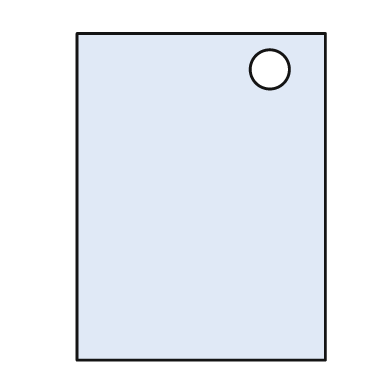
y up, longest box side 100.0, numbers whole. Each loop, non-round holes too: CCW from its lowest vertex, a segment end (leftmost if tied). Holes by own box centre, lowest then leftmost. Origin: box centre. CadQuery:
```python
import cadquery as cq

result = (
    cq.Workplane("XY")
    .moveTo(-38.0, -50.0)
    .lineTo(38.0, -50.0)
    .lineTo(38.0, 50.0)
    .lineTo(-38.0, 50.0)
    .close()
    .moveTo(21.0, 39.0)
    .circle(6.0)
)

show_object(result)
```